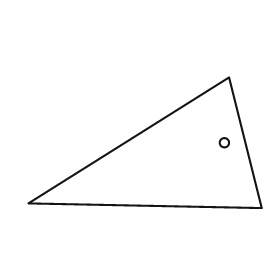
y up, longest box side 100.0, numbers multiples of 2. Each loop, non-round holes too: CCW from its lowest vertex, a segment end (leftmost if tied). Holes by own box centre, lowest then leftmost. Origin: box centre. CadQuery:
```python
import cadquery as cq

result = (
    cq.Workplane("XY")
    .moveTo(50.0, -28.0)
    .lineTo(36.0, 28.0)
    .lineTo(-50.0, -26.0)
    .close()
    .moveTo(34.0, 0.0)
    .circle(2.0)
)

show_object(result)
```